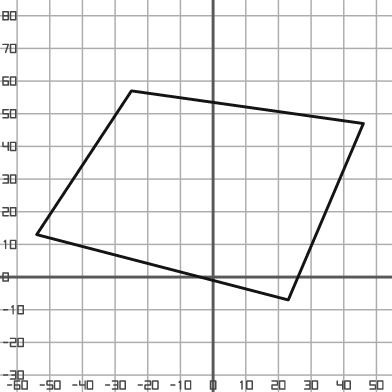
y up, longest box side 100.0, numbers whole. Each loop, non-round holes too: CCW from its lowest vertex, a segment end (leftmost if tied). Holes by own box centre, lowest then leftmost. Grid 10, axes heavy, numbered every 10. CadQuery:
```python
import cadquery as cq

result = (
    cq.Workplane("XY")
    .moveTo(23.0, -7.0)
    .lineTo(46.0, 47.0)
    .lineTo(-25.0, 57.0)
    .lineTo(-54.0, 13.0)
    .close()
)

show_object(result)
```